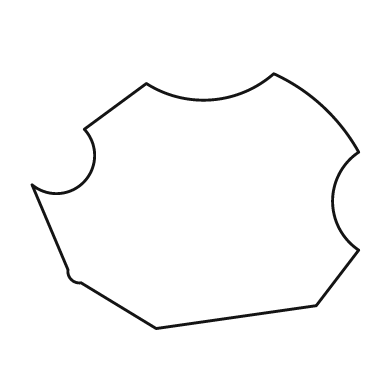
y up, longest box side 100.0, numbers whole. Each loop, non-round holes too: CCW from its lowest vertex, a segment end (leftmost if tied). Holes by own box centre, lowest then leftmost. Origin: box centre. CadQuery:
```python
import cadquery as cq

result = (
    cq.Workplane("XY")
    .moveTo(-12.0, -39.0)
    .lineTo(37.0, -32.0)
    .lineTo(50.0, -15.0)
    .threePointArc((42.0, 0.0), (50.0, 15.0))
    .threePointArc((39.0, 29.0), (24.0, 39.0))
    .threePointArc((5.0, 31.0), (-15.0, 36.0))
    .lineTo(-34.0, 22.0)
    .threePointArc((-34.0, 6.0), (-50.0, 5.0))
    .lineTo(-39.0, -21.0)
    .threePointArc((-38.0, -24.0), (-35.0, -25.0))
    .close()
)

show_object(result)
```